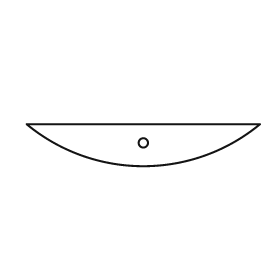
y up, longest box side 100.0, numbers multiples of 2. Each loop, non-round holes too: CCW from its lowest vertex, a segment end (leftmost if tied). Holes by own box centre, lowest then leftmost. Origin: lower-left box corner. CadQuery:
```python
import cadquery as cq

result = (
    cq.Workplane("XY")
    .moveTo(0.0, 18.0)
    .threePointArc((50.0, 0.0), (100.0, 18.0))
    .close()
    .moveTo(50.0, 10.0)
    .circle(2.0)
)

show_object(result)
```